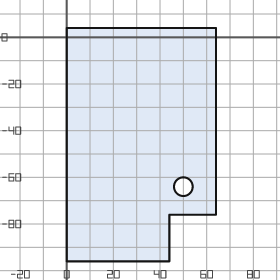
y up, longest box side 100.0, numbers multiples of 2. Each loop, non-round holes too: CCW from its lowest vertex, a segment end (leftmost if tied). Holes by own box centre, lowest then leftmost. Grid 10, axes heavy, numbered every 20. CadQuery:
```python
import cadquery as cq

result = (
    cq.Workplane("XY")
    .moveTo(0.0, -96.0)
    .lineTo(44.0, -96.0)
    .lineTo(44.0, -76.0)
    .lineTo(64.0, -76.0)
    .lineTo(64.0, 4.0)
    .lineTo(0.0, 4.0)
    .close()
    .moveTo(50.0, -64.0)
    .circle(4.0)
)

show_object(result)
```